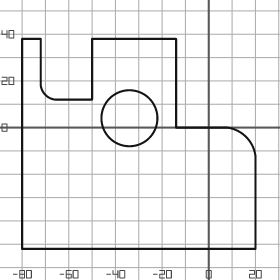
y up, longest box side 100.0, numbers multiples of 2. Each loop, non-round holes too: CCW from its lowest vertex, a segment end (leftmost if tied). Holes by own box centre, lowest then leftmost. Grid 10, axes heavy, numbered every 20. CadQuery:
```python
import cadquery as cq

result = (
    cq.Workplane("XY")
    .moveTo(-80.0, -52.0)
    .lineTo(20.0, -52.0)
    .lineTo(20.0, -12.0)
    .threePointArc((16.0, -4.0), (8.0, 0.0))
    .lineTo(-14.0, 0.0)
    .lineTo(-14.0, 38.0)
    .lineTo(-50.0, 38.0)
    .lineTo(-50.0, 12.0)
    .lineTo(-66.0, 12.0)
    .threePointArc((-70.0, 14.0), (-72.0, 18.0))
    .lineTo(-72.0, 38.0)
    .lineTo(-80.0, 38.0)
    .close()
    .moveTo(-34.0, 4.0)
    .circle(12.0)
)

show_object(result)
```